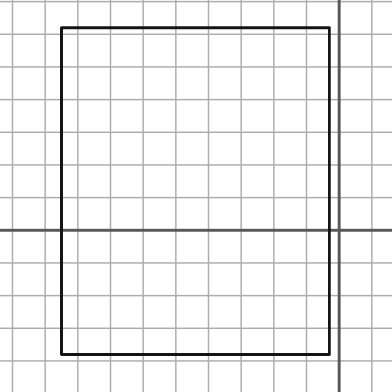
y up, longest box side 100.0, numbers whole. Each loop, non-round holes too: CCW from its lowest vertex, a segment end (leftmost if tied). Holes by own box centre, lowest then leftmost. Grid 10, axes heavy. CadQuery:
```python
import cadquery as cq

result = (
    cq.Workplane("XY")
    .moveTo(-85.0, -38.0)
    .lineTo(-3.0, -38.0)
    .lineTo(-3.0, 62.0)
    .lineTo(-85.0, 62.0)
    .close()
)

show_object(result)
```